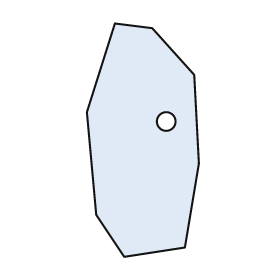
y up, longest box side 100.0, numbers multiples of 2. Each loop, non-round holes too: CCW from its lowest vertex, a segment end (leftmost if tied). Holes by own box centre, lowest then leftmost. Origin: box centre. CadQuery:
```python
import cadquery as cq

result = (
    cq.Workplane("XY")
    .moveTo(-8.0, -50.0)
    .lineTo(18.0, -46.0)
    .lineTo(24.0, -10.0)
    .lineTo(22.0, 28.0)
    .lineTo(4.0, 48.0)
    .lineTo(-12.0, 50.0)
    .lineTo(-24.0, 12.0)
    .lineTo(-20.0, -32.0)
    .close()
    .moveTo(10.0, 8.0)
    .circle(4.0)
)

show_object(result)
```